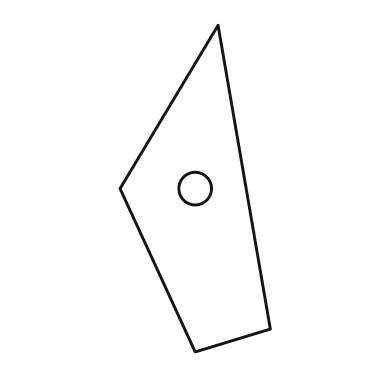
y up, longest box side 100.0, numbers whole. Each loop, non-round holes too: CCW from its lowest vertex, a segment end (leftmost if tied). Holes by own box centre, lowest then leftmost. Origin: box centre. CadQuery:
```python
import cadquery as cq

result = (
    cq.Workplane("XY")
    .moveTo(0.0, -50.0)
    .lineTo(23.0, -43.0)
    .lineTo(7.0, 50.0)
    .lineTo(-23.0, 0.0)
    .close()
    .moveTo(0.0, 0.0)
    .circle(5.0)
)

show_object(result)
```